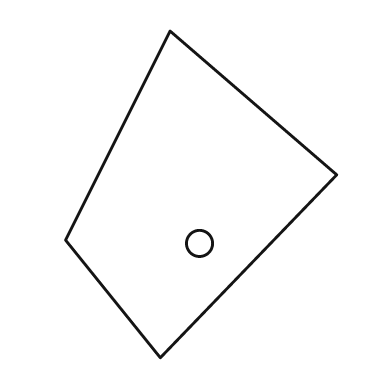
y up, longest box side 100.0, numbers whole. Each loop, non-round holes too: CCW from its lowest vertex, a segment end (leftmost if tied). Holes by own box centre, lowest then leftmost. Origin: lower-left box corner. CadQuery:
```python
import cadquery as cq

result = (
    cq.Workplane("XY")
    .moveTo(29.0, 0.0)
    .lineTo(83.0, 56.0)
    .lineTo(32.0, 100.0)
    .lineTo(0.0, 36.0)
    .close()
    .moveTo(41.0, 35.0)
    .circle(4.0)
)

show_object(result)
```